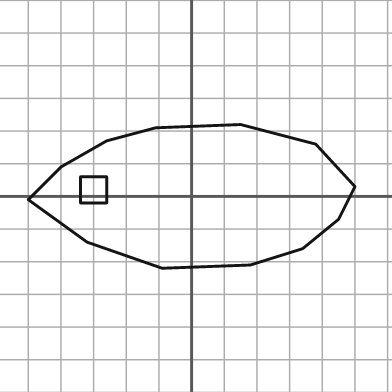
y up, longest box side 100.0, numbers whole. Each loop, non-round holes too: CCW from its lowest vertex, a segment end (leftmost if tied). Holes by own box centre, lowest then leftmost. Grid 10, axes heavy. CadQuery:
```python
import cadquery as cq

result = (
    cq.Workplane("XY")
    .moveTo(-9.0, -22.0)
    .lineTo(18.0, -21.0)
    .lineTo(34.0, -16.0)
    .lineTo(45.0, -7.0)
    .lineTo(50.0, 3.0)
    .lineTo(38.0, 16.0)
    .lineTo(15.0, 22.0)
    .lineTo(-11.0, 21.0)
    .lineTo(-26.0, 17.0)
    .lineTo(-40.0, 9.0)
    .lineTo(-50.0, -1.0)
    .lineTo(-32.0, -14.0)
    .close()
    .moveTo(-34.0, -2.0)
    .lineTo(-26.0, -2.0)
    .lineTo(-26.0, 6.0)
    .lineTo(-34.0, 6.0)
    .close()
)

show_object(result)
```